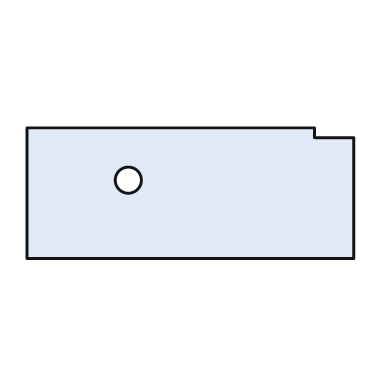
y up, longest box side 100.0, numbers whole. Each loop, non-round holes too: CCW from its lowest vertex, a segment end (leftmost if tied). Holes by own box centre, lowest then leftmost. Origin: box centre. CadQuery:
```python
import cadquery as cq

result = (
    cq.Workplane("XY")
    .moveTo(-50.0, -20.0)
    .lineTo(50.0, -20.0)
    .lineTo(50.0, 17.0)
    .lineTo(38.0, 17.0)
    .lineTo(38.0, 20.0)
    .lineTo(-50.0, 20.0)
    .close()
    .moveTo(-19.0, 4.0)
    .circle(4.0)
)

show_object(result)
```